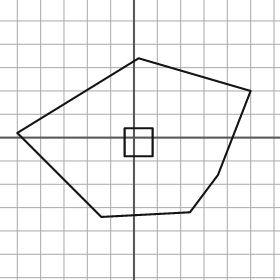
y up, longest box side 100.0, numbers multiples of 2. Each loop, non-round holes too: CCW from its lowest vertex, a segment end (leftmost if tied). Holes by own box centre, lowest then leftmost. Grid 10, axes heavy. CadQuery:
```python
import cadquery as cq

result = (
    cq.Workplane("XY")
    .moveTo(-14.0, -34.0)
    .lineTo(24.0, -32.0)
    .lineTo(36.0, -16.0)
    .lineTo(50.0, 20.0)
    .lineTo(2.0, 34.0)
    .lineTo(-50.0, 2.0)
    .close()
    .moveTo(-4.0, -8.0)
    .lineTo(8.0, -8.0)
    .lineTo(8.0, 4.0)
    .lineTo(-4.0, 4.0)
    .close()
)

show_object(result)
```